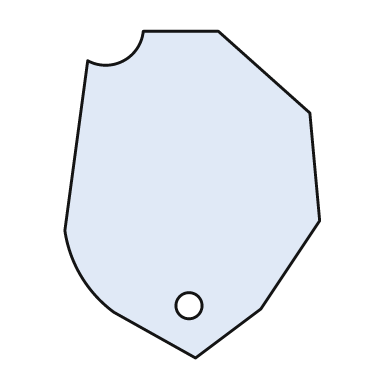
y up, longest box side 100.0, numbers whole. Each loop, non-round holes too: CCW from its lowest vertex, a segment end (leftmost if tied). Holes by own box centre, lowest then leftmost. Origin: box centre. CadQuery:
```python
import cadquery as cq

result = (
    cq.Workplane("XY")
    .moveTo(1.0, -50.0)
    .lineTo(21.0, -35.0)
    .lineTo(39.0, -8.0)
    .lineTo(36.0, 25.0)
    .lineTo(8.0, 50.0)
    .lineTo(-15.0, 50.0)
    .threePointArc((-21.0, 41.0), (-32.0, 41.0))
    .lineTo(-39.0, -11.0)
    .threePointArc((-34.0, -25.0), (-24.0, -36.0))
    .close()
    .moveTo(-1.0, -34.0)
    .circle(4.0)
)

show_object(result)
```